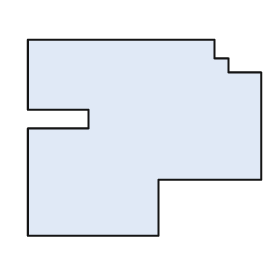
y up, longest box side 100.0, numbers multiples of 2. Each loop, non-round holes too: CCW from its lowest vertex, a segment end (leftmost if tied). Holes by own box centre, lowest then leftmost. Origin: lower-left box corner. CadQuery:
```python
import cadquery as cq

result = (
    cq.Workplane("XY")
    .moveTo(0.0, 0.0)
    .lineTo(56.0, 0.0)
    .lineTo(56.0, 24.0)
    .lineTo(100.0, 24.0)
    .lineTo(100.0, 70.0)
    .lineTo(86.0, 70.0)
    .lineTo(86.0, 76.0)
    .lineTo(80.0, 76.0)
    .lineTo(80.0, 84.0)
    .lineTo(0.0, 84.0)
    .lineTo(0.0, 54.0)
    .lineTo(26.0, 54.0)
    .lineTo(26.0, 46.0)
    .lineTo(0.0, 46.0)
    .close()
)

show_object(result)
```